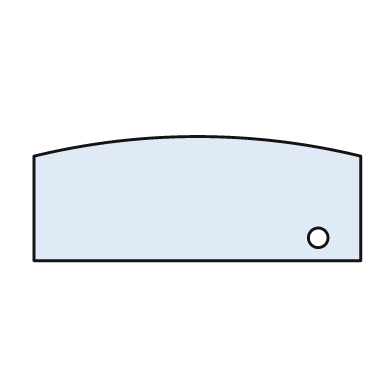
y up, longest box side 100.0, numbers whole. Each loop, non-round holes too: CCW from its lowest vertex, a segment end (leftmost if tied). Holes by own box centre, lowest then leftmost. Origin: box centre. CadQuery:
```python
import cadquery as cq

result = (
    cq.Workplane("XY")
    .moveTo(-50.0, -19.0)
    .lineTo(50.0, -19.0)
    .lineTo(50.0, 13.0)
    .threePointArc((0.0, 19.0), (-50.0, 13.0))
    .close()
    .moveTo(37.0, -12.0)
    .circle(3.0)
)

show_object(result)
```